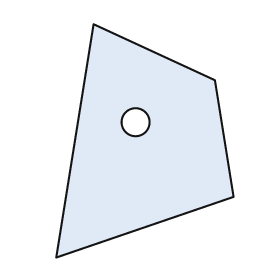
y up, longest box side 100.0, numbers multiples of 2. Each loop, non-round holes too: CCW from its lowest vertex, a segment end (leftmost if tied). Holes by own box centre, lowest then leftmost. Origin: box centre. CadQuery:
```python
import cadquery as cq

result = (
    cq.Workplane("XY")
    .moveTo(-38.0, -50.0)
    .lineTo(38.0, -24.0)
    .lineTo(30.0, 26.0)
    .lineTo(-22.0, 50.0)
    .close()
    .moveTo(-4.0, 8.0)
    .circle(6.0)
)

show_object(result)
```